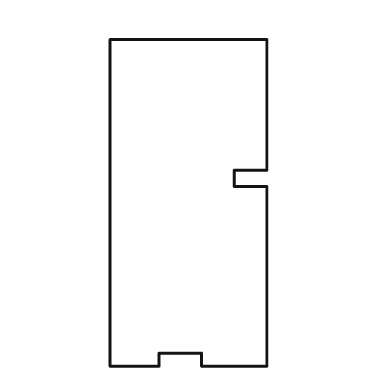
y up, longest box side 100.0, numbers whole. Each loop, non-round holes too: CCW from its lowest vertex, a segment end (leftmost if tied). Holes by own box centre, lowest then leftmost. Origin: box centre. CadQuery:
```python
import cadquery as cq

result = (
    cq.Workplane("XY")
    .moveTo(-24.0, -50.0)
    .lineTo(-9.0, -50.0)
    .lineTo(-9.0, -46.0)
    .lineTo(4.0, -46.0)
    .lineTo(4.0, -50.0)
    .lineTo(24.0, -50.0)
    .lineTo(24.0, 5.0)
    .lineTo(14.0, 5.0)
    .lineTo(14.0, 10.0)
    .lineTo(24.0, 10.0)
    .lineTo(24.0, 50.0)
    .lineTo(-24.0, 50.0)
    .close()
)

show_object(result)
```